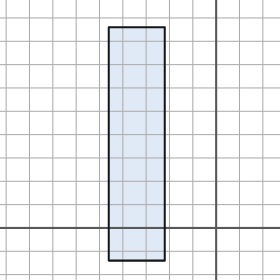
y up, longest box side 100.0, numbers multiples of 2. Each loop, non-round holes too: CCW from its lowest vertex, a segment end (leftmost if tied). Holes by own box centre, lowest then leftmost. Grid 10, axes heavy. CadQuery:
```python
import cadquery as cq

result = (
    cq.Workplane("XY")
    .moveTo(-46.0, -14.0)
    .lineTo(-22.0, -14.0)
    .lineTo(-22.0, 86.0)
    .lineTo(-46.0, 86.0)
    .close()
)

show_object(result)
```